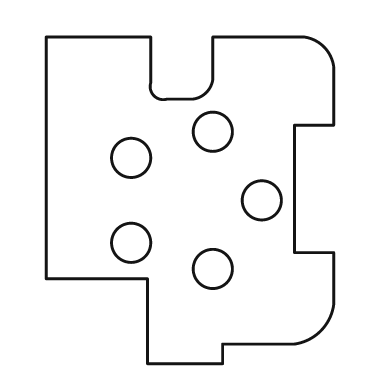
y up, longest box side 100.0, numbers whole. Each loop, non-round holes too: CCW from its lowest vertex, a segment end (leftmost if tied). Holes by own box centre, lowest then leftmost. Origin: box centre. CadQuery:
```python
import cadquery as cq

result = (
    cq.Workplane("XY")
    .moveTo(-13.0, -50.0)
    .lineTo(10.0, -50.0)
    .lineTo(10.0, -44.0)
    .lineTo(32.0, -44.0)
    .threePointArc((40.0, -40.0), (44.0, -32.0))
    .lineTo(44.0, -16.0)
    .lineTo(32.0, -16.0)
    .lineTo(32.0, 23.0)
    .lineTo(44.0, 23.0)
    .lineTo(44.0, 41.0)
    .threePointArc((41.0, 47.0), (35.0, 50.0))
    .lineTo(7.0, 50.0)
    .lineTo(7.0, 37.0)
    .threePointArc((5.0, 33.0), (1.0, 31.0))
    .lineTo(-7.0, 31.0)
    .threePointArc((-11.0, 32.0), (-12.0, 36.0))
    .lineTo(-12.0, 50.0)
    .lineTo(-44.0, 50.0)
    .lineTo(-44.0, -24.0)
    .lineTo(-13.0, -24.0)
    .close()
    .moveTo(7.0, -21.0)
    .circle(6.0)
    .moveTo(-18.0, -13.0)
    .circle(6.0)
    .moveTo(22.0, 0.0)
    .circle(6.0)
    .moveTo(-18.0, 13.0)
    .circle(6.0)
    .moveTo(7.0, 21.0)
    .circle(6.0)
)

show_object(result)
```